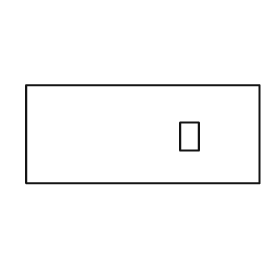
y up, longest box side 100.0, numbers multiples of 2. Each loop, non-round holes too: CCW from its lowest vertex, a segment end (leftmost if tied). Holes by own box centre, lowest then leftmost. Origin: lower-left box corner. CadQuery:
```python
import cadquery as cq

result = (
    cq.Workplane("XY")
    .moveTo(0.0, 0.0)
    .lineTo(100.0, 0.0)
    .lineTo(100.0, 42.0)
    .lineTo(0.0, 42.0)
    .close()
    .moveTo(66.0, 14.0)
    .lineTo(74.0, 14.0)
    .lineTo(74.0, 26.0)
    .lineTo(66.0, 26.0)
    .close()
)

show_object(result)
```